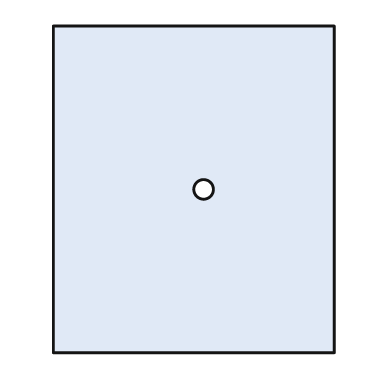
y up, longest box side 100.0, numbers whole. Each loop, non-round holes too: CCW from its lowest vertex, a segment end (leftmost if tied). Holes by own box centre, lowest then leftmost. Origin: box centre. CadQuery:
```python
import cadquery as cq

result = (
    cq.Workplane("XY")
    .moveTo(-43.0, -50.0)
    .lineTo(43.0, -50.0)
    .lineTo(43.0, 50.0)
    .lineTo(-43.0, 50.0)
    .close()
    .moveTo(3.0, 0.0)
    .circle(3.0)
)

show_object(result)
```